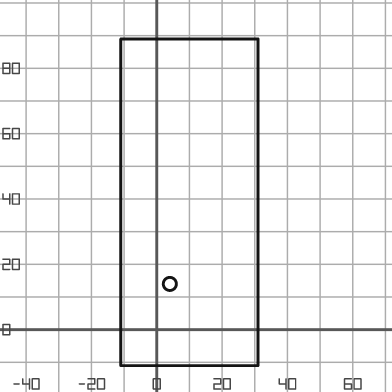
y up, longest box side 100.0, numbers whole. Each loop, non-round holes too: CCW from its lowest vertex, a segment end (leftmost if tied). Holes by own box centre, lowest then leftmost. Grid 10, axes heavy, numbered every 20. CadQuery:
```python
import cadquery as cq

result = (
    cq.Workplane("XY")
    .moveTo(-11.0, -11.0)
    .lineTo(31.0, -11.0)
    .lineTo(31.0, 89.0)
    .lineTo(-11.0, 89.0)
    .close()
    .moveTo(4.0, 14.0)
    .circle(2.0)
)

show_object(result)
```